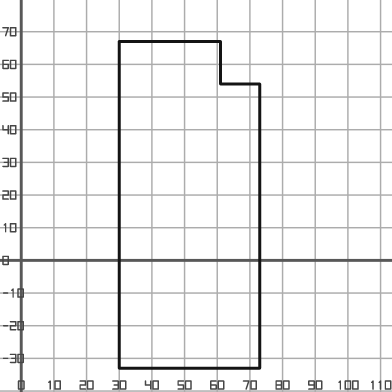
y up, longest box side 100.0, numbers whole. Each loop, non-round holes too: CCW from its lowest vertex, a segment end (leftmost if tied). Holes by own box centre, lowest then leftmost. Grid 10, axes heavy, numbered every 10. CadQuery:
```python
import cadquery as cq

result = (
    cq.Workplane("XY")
    .moveTo(30.0, -33.0)
    .lineTo(73.0, -33.0)
    .lineTo(73.0, 54.0)
    .lineTo(61.0, 54.0)
    .lineTo(61.0, 67.0)
    .lineTo(30.0, 67.0)
    .close()
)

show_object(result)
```